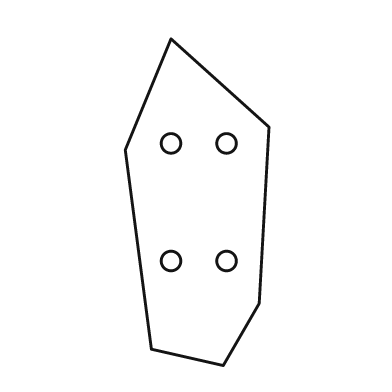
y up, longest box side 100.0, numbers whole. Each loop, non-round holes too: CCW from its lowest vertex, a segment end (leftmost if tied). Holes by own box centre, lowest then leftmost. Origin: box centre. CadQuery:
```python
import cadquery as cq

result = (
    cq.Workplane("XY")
    .moveTo(8.0, -50.0)
    .lineTo(19.0, -31.0)
    .lineTo(22.0, 23.0)
    .lineTo(-8.0, 50.0)
    .lineTo(-22.0, 16.0)
    .lineTo(-14.0, -45.0)
    .close()
    .moveTo(-8.0, -18.0)
    .circle(3.0)
    .moveTo(9.0, -18.0)
    .circle(3.0)
    .moveTo(-8.0, 18.0)
    .circle(3.0)
    .moveTo(9.0, 18.0)
    .circle(3.0)
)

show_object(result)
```